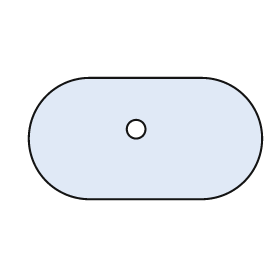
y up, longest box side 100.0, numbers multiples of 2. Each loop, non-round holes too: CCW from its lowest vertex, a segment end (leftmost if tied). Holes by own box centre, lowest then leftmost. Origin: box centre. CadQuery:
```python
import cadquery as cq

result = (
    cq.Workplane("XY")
    .moveTo(-24.0, -26.0)
    .lineTo(24.0, -26.0)
    .threePointArc((50.0, 0.0), (24.0, 26.0))
    .lineTo(-24.0, 26.0)
    .threePointArc((-50.0, 0.0), (-24.0, -26.0))
    .close()
    .moveTo(-4.0, 4.0)
    .circle(4.0)
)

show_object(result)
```